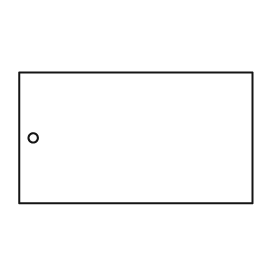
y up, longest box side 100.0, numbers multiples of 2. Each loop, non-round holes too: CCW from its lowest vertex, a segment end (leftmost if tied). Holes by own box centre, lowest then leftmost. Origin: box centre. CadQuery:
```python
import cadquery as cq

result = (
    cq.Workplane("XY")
    .moveTo(-50.0, -28.0)
    .lineTo(50.0, -28.0)
    .lineTo(50.0, 28.0)
    .lineTo(-50.0, 28.0)
    .close()
    .moveTo(-44.0, 0.0)
    .circle(2.0)
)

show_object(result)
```